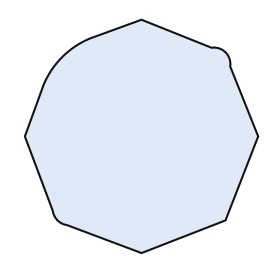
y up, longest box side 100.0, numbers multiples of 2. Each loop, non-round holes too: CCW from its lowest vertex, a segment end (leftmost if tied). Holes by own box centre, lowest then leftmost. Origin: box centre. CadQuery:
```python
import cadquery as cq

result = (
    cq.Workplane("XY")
    .moveTo(0.0, -50.0)
    .lineTo(36.0, -36.0)
    .lineTo(50.0, 0.0)
    .lineTo(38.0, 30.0)
    .threePointArc((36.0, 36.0), (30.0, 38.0))
    .lineTo(0.0, 50.0)
    .lineTo(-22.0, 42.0)
    .threePointArc((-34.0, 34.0), (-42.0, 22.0))
    .lineTo(-50.0, 0.0)
    .lineTo(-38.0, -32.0)
    .threePointArc((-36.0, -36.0), (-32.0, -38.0))
    .close()
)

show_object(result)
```